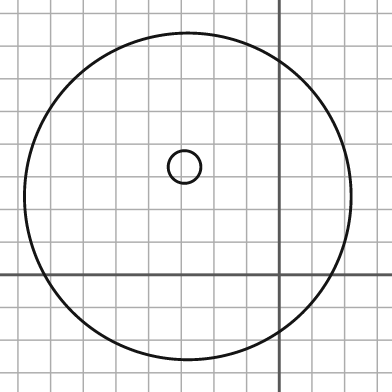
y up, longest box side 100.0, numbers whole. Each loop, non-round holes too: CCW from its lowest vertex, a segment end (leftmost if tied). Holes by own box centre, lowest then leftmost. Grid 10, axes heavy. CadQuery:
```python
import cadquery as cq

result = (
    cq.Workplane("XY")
    .moveTo(-28.0, 24.0)
    .circle(50.0)
    .moveTo(-29.0, 33.0)
    .circle(5.0)
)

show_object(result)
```